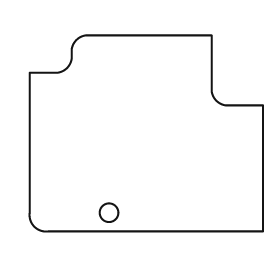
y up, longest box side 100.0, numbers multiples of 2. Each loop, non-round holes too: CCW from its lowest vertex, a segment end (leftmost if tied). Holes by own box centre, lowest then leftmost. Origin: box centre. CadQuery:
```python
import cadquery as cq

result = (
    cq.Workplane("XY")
    .moveTo(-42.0, -42.0)
    .lineTo(50.0, -42.0)
    .lineTo(50.0, 12.0)
    .lineTo(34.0, 12.0)
    .threePointArc((30.0, 14.0), (28.0, 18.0))
    .lineTo(28.0, 42.0)
    .lineTo(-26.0, 42.0)
    .threePointArc((-30.0, 40.0), (-32.0, 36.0))
    .lineTo(-32.0, 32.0)
    .threePointArc((-34.0, 28.0), (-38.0, 26.0))
    .lineTo(-50.0, 26.0)
    .lineTo(-50.0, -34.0)
    .threePointArc((-48.0, -40.0), (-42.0, -42.0))
    .close()
    .moveTo(-16.0, -34.0)
    .circle(4.0)
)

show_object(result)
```